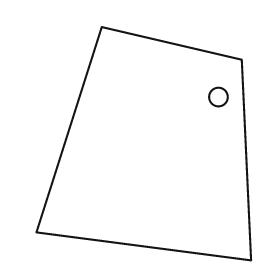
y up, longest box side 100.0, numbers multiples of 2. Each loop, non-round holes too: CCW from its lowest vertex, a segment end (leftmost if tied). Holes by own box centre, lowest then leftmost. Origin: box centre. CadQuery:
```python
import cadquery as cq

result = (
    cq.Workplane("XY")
    .moveTo(46.0, -50.0)
    .lineTo(42.0, 36.0)
    .lineTo(-18.0, 50.0)
    .lineTo(-46.0, -38.0)
    .close()
    .moveTo(32.0, 20.0)
    .circle(4.0)
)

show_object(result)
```